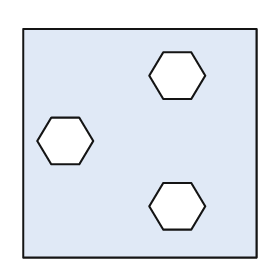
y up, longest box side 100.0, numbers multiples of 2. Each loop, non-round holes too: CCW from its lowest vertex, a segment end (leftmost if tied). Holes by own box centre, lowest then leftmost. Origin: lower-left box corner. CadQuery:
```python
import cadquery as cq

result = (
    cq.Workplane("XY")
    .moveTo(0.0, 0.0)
    .lineTo(100.0, 0.0)
    .lineTo(100.0, 98.0)
    .lineTo(0.0, 98.0)
    .close()
    .moveTo(60.0, 12.0)
    .lineTo(72.0, 12.0)
    .lineTo(78.0, 22.0)
    .lineTo(72.0, 32.0)
    .lineTo(60.0, 32.0)
    .lineTo(54.0, 22.0)
    .close()
    .moveTo(12.0, 40.0)
    .lineTo(24.0, 40.0)
    .lineTo(30.0, 50.0)
    .lineTo(24.0, 60.0)
    .lineTo(12.0, 60.0)
    .lineTo(6.0, 50.0)
    .close()
    .moveTo(60.0, 68.0)
    .lineTo(72.0, 68.0)
    .lineTo(78.0, 78.0)
    .lineTo(72.0, 88.0)
    .lineTo(60.0, 88.0)
    .lineTo(54.0, 78.0)
    .close()
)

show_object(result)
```